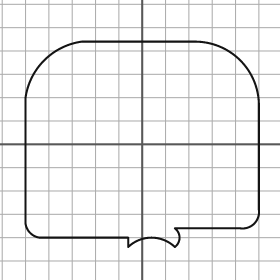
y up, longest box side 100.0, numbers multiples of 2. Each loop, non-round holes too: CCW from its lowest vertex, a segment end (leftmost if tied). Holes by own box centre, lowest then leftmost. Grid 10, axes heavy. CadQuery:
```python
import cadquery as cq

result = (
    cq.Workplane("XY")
    .moveTo(-6.0, -44.0)
    .threePointArc((4.0, -40.0), (14.0, -44.0))
    .threePointArc((16.0, -40.0), (14.0, -36.0))
    .lineTo(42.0, -36.0)
    .threePointArc((48.0, -34.0), (50.0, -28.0))
    .lineTo(50.0, 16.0)
    .threePointArc((42.0, 36.0), (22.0, 44.0))
    .lineTo(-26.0, 44.0)
    .threePointArc((-42.0, 36.0), (-50.0, 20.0))
    .lineTo(-50.0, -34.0)
    .threePointArc((-48.0, -38.0), (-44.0, -40.0))
    .lineTo(-6.0, -40.0)
    .close()
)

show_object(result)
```